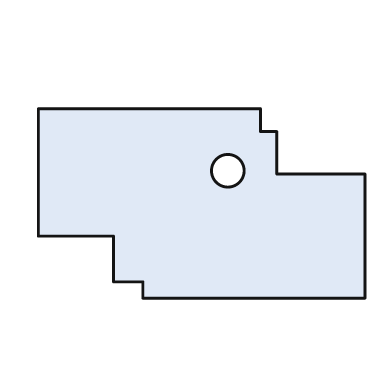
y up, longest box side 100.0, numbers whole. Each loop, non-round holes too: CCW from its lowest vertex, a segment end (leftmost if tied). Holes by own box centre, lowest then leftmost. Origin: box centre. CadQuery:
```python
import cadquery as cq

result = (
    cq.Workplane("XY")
    .moveTo(-18.0, -29.0)
    .lineTo(50.0, -29.0)
    .lineTo(50.0, 9.0)
    .lineTo(23.0, 9.0)
    .lineTo(23.0, 22.0)
    .lineTo(18.0, 22.0)
    .lineTo(18.0, 29.0)
    .lineTo(-50.0, 29.0)
    .lineTo(-50.0, -10.0)
    .lineTo(-27.0, -10.0)
    .lineTo(-27.0, -24.0)
    .lineTo(-18.0, -24.0)
    .close()
    .moveTo(8.0, 10.0)
    .circle(5.0)
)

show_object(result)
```